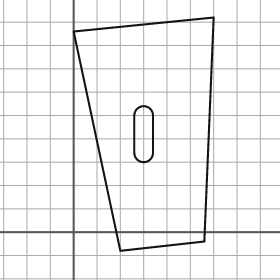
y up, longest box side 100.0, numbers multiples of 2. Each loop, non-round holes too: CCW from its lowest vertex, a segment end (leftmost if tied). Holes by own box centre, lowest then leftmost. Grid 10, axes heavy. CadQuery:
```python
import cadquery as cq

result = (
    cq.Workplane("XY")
    .moveTo(20.0, -8.0)
    .lineTo(56.0, -4.0)
    .lineTo(60.0, 92.0)
    .lineTo(0.0, 86.0)
    .close()
    .moveTo(26.0, 34.0)
    .threePointArc((30.0, 30.0), (34.0, 34.0))
    .lineTo(34.0, 50.0)
    .threePointArc((30.0, 54.0), (26.0, 50.0))
    .close()
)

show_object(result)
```